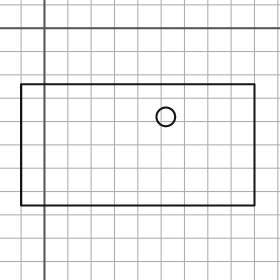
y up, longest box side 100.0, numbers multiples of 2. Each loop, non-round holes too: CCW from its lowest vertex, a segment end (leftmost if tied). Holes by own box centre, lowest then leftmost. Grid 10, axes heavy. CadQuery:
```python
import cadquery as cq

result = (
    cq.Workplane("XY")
    .moveTo(-10.0, -76.0)
    .lineTo(90.0, -76.0)
    .lineTo(90.0, -24.0)
    .lineTo(-10.0, -24.0)
    .close()
    .moveTo(52.0, -38.0)
    .circle(4.0)
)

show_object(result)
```